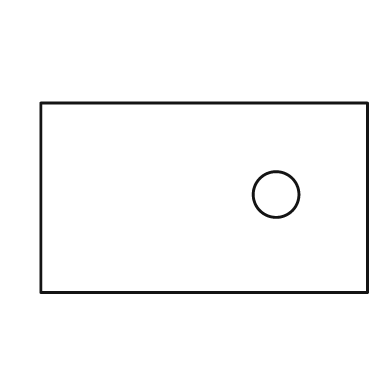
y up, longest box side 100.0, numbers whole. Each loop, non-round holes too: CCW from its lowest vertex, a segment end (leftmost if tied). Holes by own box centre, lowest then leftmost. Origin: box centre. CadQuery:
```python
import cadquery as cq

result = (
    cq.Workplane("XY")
    .moveTo(-50.0, -29.0)
    .lineTo(50.0, -29.0)
    .lineTo(50.0, 29.0)
    .lineTo(-50.0, 29.0)
    .close()
    .moveTo(22.0, 1.0)
    .circle(7.0)
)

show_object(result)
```